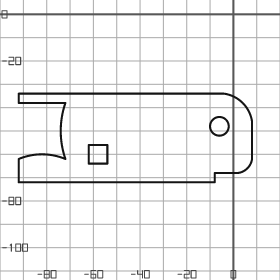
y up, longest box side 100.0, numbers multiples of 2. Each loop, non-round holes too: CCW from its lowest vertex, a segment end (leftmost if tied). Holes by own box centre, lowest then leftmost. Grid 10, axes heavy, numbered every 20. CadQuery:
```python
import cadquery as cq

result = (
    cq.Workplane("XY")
    .moveTo(-92.0, -72.0)
    .lineTo(-8.0, -72.0)
    .lineTo(-8.0, -68.0)
    .lineTo(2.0, -68.0)
    .threePointArc((6.0, -66.0), (8.0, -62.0))
    .lineTo(8.0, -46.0)
    .threePointArc((4.0, -38.0), (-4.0, -34.0))
    .lineTo(-92.0, -34.0)
    .lineTo(-92.0, -38.0)
    .lineTo(-72.0, -38.0)
    .threePointArc((-74.0, -50.0), (-72.0, -62.0))
    .threePointArc((-82.0, -60.0), (-92.0, -62.0))
    .close()
    .moveTo(-62.0, -64.0)
    .lineTo(-54.0, -64.0)
    .lineTo(-54.0, -56.0)
    .lineTo(-62.0, -56.0)
    .close()
    .moveTo(-6.0, -48.0)
    .circle(4.0)
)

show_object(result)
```